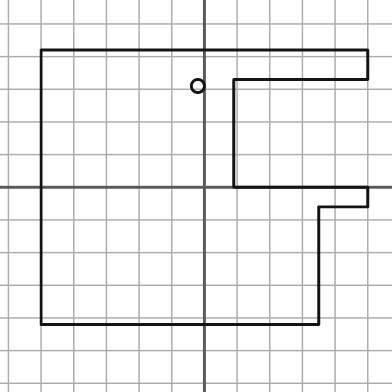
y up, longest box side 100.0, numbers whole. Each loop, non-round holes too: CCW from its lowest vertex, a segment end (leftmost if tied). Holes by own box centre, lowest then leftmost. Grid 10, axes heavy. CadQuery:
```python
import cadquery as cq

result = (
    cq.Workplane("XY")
    .moveTo(-50.0, -42.0)
    .lineTo(35.0, -42.0)
    .lineTo(35.0, -6.0)
    .lineTo(50.0, -6.0)
    .lineTo(50.0, 0.0)
    .lineTo(9.0, 0.0)
    .lineTo(9.0, 33.0)
    .lineTo(50.0, 33.0)
    .lineTo(50.0, 42.0)
    .lineTo(-50.0, 42.0)
    .close()
    .moveTo(-2.0, 31.0)
    .circle(2.0)
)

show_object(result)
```